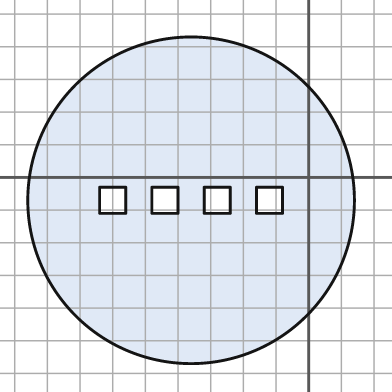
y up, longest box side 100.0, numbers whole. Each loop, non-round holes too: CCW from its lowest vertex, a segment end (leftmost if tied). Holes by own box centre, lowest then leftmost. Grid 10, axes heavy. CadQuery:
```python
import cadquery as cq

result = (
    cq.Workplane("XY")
    .moveTo(-36.0, -7.0)
    .circle(50.0)
    .moveTo(-64.0, -11.0)
    .lineTo(-56.0, -11.0)
    .lineTo(-56.0, -3.0)
    .lineTo(-64.0, -3.0)
    .close()
    .moveTo(-48.0, -11.0)
    .lineTo(-40.0, -11.0)
    .lineTo(-40.0, -3.0)
    .lineTo(-48.0, -3.0)
    .close()
    .moveTo(-32.0, -11.0)
    .lineTo(-24.0, -11.0)
    .lineTo(-24.0, -3.0)
    .lineTo(-32.0, -3.0)
    .close()
    .moveTo(-16.0, -11.0)
    .lineTo(-8.0, -11.0)
    .lineTo(-8.0, -3.0)
    .lineTo(-16.0, -3.0)
    .close()
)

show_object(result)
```